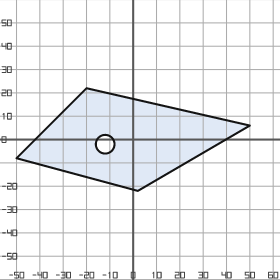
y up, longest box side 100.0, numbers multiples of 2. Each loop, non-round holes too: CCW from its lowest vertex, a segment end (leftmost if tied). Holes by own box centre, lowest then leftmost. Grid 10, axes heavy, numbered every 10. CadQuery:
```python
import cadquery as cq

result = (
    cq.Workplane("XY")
    .moveTo(2.0, -22.0)
    .lineTo(50.0, 6.0)
    .lineTo(-20.0, 22.0)
    .lineTo(-50.0, -8.0)
    .close()
    .moveTo(-12.0, -2.0)
    .circle(4.0)
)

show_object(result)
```